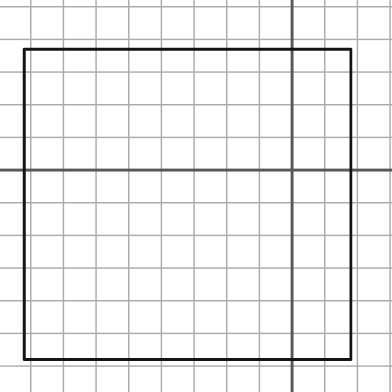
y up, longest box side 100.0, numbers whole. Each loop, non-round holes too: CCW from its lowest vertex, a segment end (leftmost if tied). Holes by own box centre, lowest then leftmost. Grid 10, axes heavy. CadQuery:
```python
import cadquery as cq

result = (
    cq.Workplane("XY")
    .moveTo(-82.0, -58.0)
    .lineTo(18.0, -58.0)
    .lineTo(18.0, 37.0)
    .lineTo(-82.0, 37.0)
    .close()
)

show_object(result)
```